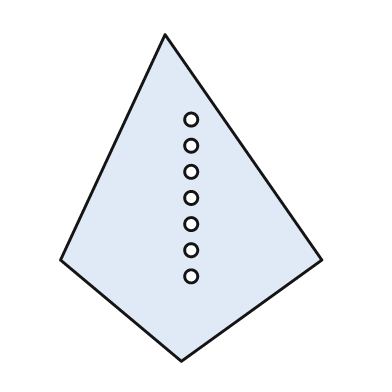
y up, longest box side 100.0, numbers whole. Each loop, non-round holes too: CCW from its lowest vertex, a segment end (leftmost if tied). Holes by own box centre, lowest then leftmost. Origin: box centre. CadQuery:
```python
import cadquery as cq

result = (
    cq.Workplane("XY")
    .moveTo(-3.0, -50.0)
    .lineTo(40.0, -19.0)
    .lineTo(-8.0, 50.0)
    .lineTo(-40.0, -19.0)
    .close()
    .moveTo(0.0, -24.0)
    .circle(2.0)
    .moveTo(0.0, -16.0)
    .circle(2.0)
    .moveTo(0.0, -8.0)
    .circle(2.0)
    .moveTo(0.0, 0.0)
    .circle(2.0)
    .moveTo(0.0, 8.0)
    .circle(2.0)
    .moveTo(0.0, 16.0)
    .circle(2.0)
    .moveTo(0.0, 24.0)
    .circle(2.0)
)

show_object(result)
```